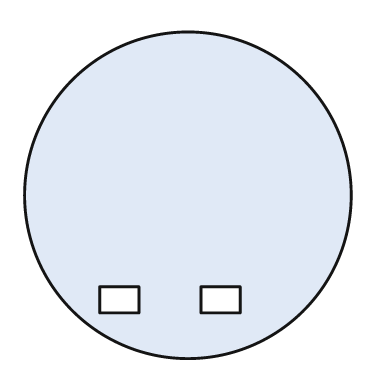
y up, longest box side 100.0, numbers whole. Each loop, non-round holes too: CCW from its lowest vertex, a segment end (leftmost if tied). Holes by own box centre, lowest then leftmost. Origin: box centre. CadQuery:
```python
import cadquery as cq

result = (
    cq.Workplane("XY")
    .moveTo(0.0, 0.0)
    .circle(50.0)
    .moveTo(-27.0, -36.0)
    .lineTo(-15.0, -36.0)
    .lineTo(-15.0, -28.0)
    .lineTo(-27.0, -28.0)
    .close()
    .moveTo(4.0, -36.0)
    .lineTo(16.0, -36.0)
    .lineTo(16.0, -28.0)
    .lineTo(4.0, -28.0)
    .close()
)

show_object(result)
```